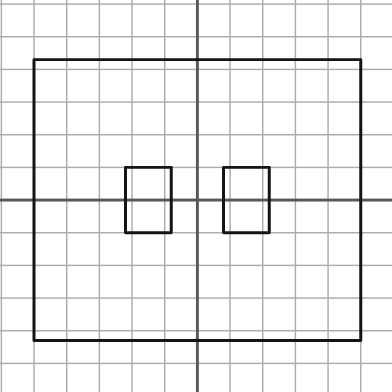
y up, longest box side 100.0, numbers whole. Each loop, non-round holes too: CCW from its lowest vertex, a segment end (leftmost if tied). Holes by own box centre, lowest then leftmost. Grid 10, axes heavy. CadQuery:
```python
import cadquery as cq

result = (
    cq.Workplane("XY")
    .moveTo(-50.0, -43.0)
    .lineTo(50.0, -43.0)
    .lineTo(50.0, 43.0)
    .lineTo(-50.0, 43.0)
    .close()
    .moveTo(-22.0, -10.0)
    .lineTo(-8.0, -10.0)
    .lineTo(-8.0, 10.0)
    .lineTo(-22.0, 10.0)
    .close()
    .moveTo(8.0, -10.0)
    .lineTo(22.0, -10.0)
    .lineTo(22.0, 10.0)
    .lineTo(8.0, 10.0)
    .close()
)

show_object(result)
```